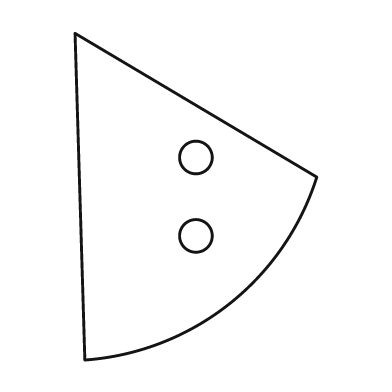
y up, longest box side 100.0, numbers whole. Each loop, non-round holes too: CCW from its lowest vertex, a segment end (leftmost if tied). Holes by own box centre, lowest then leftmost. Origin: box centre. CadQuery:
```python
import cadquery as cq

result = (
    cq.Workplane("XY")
    .moveTo(-34.0, -50.0)
    .threePointArc((10.0, -33.0), (37.0, 6.0))
    .lineTo(-37.0, 50.0)
    .close()
    .moveTo(0.0, -12.0)
    .circle(5.0)
    .moveTo(0.0, 12.0)
    .circle(5.0)
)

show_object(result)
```